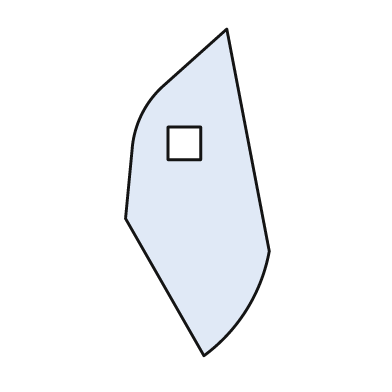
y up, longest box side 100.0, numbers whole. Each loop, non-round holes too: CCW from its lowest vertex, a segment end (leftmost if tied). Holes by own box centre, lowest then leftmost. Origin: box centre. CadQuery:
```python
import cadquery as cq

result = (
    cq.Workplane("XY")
    .moveTo(2.0, -50.0)
    .threePointArc((15.0, -36.0), (22.0, -18.0))
    .lineTo(9.0, 50.0)
    .lineTo(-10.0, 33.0)
    .threePointArc((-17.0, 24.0), (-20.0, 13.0))
    .lineTo(-22.0, -8.0)
    .close()
    .moveTo(-9.0, 10.0)
    .lineTo(1.0, 10.0)
    .lineTo(1.0, 20.0)
    .lineTo(-9.0, 20.0)
    .close()
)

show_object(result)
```